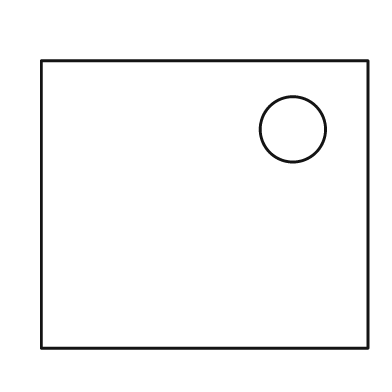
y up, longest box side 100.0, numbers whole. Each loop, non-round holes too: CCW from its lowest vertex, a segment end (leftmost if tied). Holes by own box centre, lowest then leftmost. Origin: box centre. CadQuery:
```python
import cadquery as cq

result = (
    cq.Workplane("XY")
    .moveTo(-50.0, -44.0)
    .lineTo(50.0, -44.0)
    .lineTo(50.0, 44.0)
    .lineTo(-50.0, 44.0)
    .close()
    .moveTo(27.0, 23.0)
    .circle(10.0)
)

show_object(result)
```